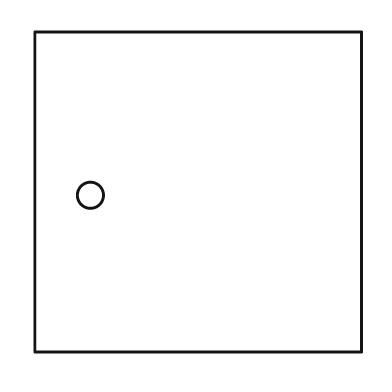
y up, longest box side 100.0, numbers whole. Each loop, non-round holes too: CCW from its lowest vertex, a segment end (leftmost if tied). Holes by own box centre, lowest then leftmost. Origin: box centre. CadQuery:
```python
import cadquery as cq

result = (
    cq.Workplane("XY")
    .moveTo(-50.0, -49.0)
    .lineTo(50.0, -49.0)
    .lineTo(50.0, 49.0)
    .lineTo(-50.0, 49.0)
    .close()
    .moveTo(-33.0, -1.0)
    .circle(4.0)
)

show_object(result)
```